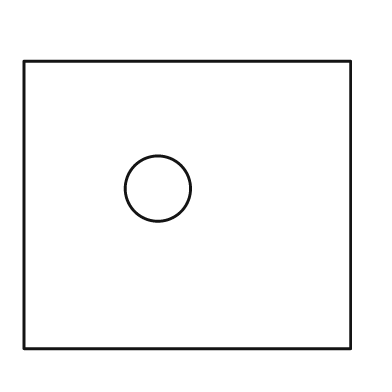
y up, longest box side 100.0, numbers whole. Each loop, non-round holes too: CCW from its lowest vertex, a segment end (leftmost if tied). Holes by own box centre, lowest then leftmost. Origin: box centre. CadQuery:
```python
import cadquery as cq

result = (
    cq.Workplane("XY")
    .moveTo(-50.0, -44.0)
    .lineTo(50.0, -44.0)
    .lineTo(50.0, 44.0)
    .lineTo(-50.0, 44.0)
    .close()
    .moveTo(-9.0, 5.0)
    .circle(10.0)
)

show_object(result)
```